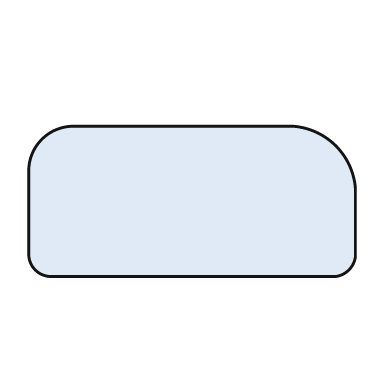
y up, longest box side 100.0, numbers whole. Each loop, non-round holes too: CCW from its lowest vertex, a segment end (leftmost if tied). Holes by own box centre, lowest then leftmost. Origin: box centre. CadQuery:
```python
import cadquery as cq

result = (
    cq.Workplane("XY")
    .moveTo(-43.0, -23.0)
    .lineTo(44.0, -23.0)
    .threePointArc((48.0, -21.0), (50.0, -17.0))
    .lineTo(50.0, 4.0)
    .threePointArc((44.0, 17.0), (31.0, 23.0))
    .lineTo(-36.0, 23.0)
    .threePointArc((-46.0, 19.0), (-50.0, 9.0))
    .lineTo(-50.0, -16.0)
    .threePointArc((-48.0, -21.0), (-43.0, -23.0))
    .close()
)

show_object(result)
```